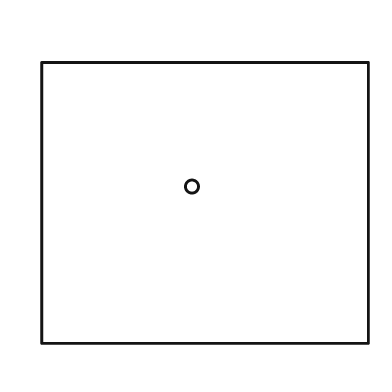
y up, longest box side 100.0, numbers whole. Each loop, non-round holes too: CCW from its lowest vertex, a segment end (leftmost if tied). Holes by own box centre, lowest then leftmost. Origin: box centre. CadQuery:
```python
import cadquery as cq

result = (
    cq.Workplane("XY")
    .moveTo(-50.0, -43.0)
    .lineTo(50.0, -43.0)
    .lineTo(50.0, 43.0)
    .lineTo(-50.0, 43.0)
    .close()
    .moveTo(-4.0, 5.0)
    .circle(2.0)
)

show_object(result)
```